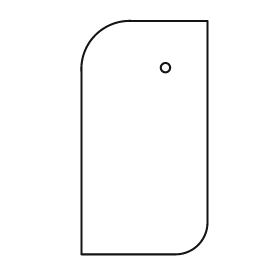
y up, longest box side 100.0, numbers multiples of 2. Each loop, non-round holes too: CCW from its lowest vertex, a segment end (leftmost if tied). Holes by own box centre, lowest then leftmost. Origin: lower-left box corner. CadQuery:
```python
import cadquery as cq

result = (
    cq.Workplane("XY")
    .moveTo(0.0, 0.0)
    .lineTo(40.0, 0.0)
    .threePointArc((50.0, 4.0), (54.0, 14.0))
    .lineTo(54.0, 100.0)
    .lineTo(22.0, 100.0)
    .threePointArc((6.0, 94.0), (0.0, 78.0))
    .close()
    .moveTo(36.0, 80.0)
    .circle(2.0)
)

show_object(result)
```